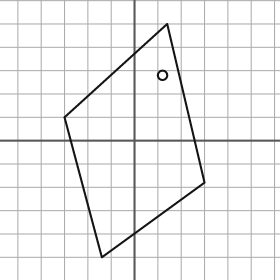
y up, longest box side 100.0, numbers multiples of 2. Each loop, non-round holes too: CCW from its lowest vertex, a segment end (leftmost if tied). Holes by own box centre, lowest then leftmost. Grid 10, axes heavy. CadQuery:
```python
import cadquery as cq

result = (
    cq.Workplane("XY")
    .moveTo(-14.0, -50.0)
    .lineTo(30.0, -18.0)
    .lineTo(14.0, 50.0)
    .lineTo(-30.0, 10.0)
    .close()
    .moveTo(12.0, 28.0)
    .circle(2.0)
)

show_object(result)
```